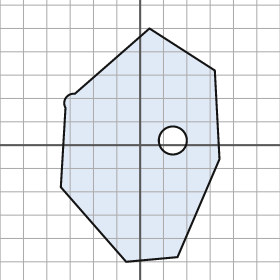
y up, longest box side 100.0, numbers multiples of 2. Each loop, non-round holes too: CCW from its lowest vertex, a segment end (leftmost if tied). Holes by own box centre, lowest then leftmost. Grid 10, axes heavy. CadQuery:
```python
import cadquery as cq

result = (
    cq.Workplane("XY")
    .moveTo(-6.0, -50.0)
    .lineTo(16.0, -48.0)
    .lineTo(34.0, -6.0)
    .lineTo(32.0, 32.0)
    .lineTo(4.0, 50.0)
    .lineTo(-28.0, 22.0)
    .threePointArc((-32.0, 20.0), (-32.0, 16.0))
    .lineTo(-34.0, -18.0)
    .close()
    .moveTo(14.0, 2.0)
    .circle(6.0)
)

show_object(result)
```